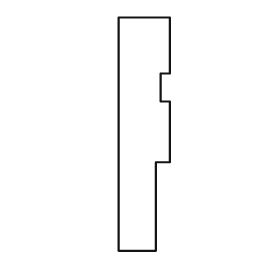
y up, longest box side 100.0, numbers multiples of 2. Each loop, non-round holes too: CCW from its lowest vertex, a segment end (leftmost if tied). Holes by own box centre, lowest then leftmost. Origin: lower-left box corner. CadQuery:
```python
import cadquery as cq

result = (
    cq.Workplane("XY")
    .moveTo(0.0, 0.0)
    .lineTo(16.0, 0.0)
    .lineTo(16.0, 38.0)
    .lineTo(22.0, 38.0)
    .lineTo(22.0, 64.0)
    .lineTo(18.0, 64.0)
    .lineTo(18.0, 76.0)
    .lineTo(22.0, 76.0)
    .lineTo(22.0, 100.0)
    .lineTo(0.0, 100.0)
    .close()
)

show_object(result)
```